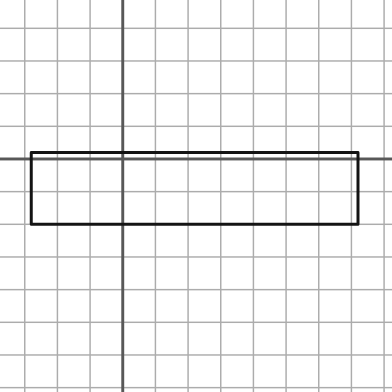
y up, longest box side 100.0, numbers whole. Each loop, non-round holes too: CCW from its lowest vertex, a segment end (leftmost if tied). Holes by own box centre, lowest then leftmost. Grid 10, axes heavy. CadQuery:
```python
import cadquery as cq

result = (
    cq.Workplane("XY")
    .moveTo(-28.0, -20.0)
    .lineTo(72.0, -20.0)
    .lineTo(72.0, 2.0)
    .lineTo(-28.0, 2.0)
    .close()
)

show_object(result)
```